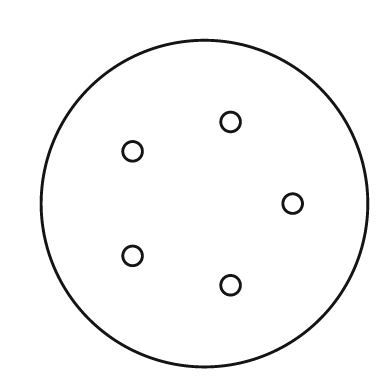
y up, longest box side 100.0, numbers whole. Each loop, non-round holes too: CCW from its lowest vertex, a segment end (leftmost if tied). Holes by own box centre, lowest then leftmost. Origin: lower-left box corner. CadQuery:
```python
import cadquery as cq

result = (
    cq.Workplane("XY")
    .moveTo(50.0, 50.0)
    .circle(50.0)
    .moveTo(58.0, 25.0)
    .circle(3.0)
    .moveTo(28.0, 34.0)
    .circle(3.0)
    .moveTo(77.0, 50.0)
    .circle(3.0)
    .moveTo(28.0, 66.0)
    .circle(3.0)
    .moveTo(58.0, 75.0)
    .circle(3.0)
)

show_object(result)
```